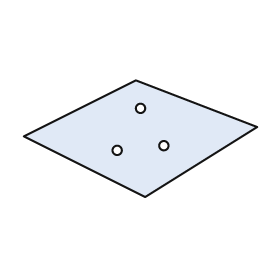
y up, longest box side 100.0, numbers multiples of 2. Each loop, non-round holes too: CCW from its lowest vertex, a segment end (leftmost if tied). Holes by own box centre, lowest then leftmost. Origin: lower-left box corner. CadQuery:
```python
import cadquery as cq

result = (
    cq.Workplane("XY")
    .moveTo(52.0, 0.0)
    .lineTo(100.0, 30.0)
    .lineTo(48.0, 50.0)
    .lineTo(0.0, 26.0)
    .close()
    .moveTo(40.0, 20.0)
    .circle(2.0)
    .moveTo(60.0, 22.0)
    .circle(2.0)
    .moveTo(50.0, 38.0)
    .circle(2.0)
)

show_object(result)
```